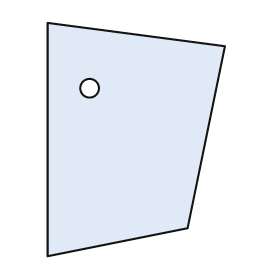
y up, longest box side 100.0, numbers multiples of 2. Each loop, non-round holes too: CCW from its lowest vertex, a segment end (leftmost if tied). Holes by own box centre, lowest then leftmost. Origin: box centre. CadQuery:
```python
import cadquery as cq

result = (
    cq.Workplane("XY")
    .moveTo(-38.0, -50.0)
    .lineTo(22.0, -38.0)
    .lineTo(38.0, 40.0)
    .lineTo(-38.0, 50.0)
    .close()
    .moveTo(-20.0, 22.0)
    .circle(4.0)
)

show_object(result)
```